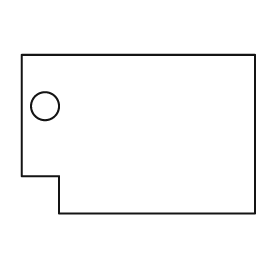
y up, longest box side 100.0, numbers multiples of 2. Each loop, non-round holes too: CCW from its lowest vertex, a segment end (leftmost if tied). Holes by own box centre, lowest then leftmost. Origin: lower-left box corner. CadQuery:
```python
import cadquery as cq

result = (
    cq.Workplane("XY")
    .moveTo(16.0, 0.0)
    .lineTo(100.0, 0.0)
    .lineTo(100.0, 68.0)
    .lineTo(0.0, 68.0)
    .lineTo(0.0, 16.0)
    .lineTo(16.0, 16.0)
    .close()
    .moveTo(10.0, 46.0)
    .circle(6.0)
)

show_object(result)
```